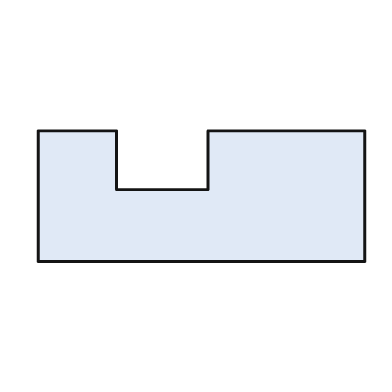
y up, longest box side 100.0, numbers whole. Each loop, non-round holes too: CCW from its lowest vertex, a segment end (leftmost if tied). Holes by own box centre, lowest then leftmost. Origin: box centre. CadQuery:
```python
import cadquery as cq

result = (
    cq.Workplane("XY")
    .moveTo(-50.0, -20.0)
    .lineTo(50.0, -20.0)
    .lineTo(50.0, 20.0)
    .lineTo(2.0, 20.0)
    .lineTo(2.0, 2.0)
    .lineTo(-26.0, 2.0)
    .lineTo(-26.0, 20.0)
    .lineTo(-50.0, 20.0)
    .close()
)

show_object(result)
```